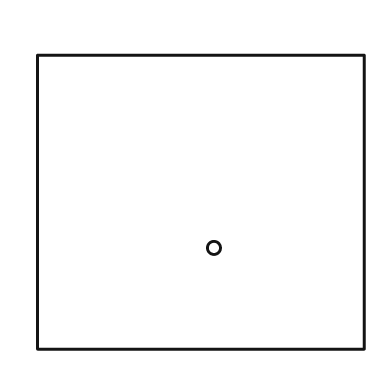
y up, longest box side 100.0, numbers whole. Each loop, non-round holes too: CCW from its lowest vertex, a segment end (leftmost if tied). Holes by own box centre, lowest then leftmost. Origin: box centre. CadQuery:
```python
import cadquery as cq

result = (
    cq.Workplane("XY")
    .moveTo(-50.0, -45.0)
    .lineTo(50.0, -45.0)
    .lineTo(50.0, 45.0)
    .lineTo(-50.0, 45.0)
    .close()
    .moveTo(4.0, -14.0)
    .circle(2.0)
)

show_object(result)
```